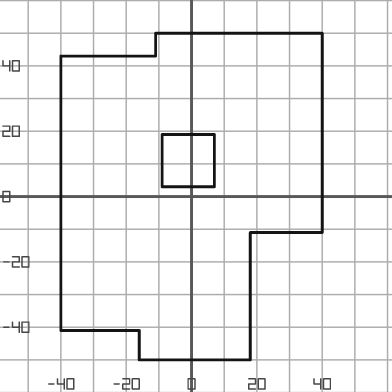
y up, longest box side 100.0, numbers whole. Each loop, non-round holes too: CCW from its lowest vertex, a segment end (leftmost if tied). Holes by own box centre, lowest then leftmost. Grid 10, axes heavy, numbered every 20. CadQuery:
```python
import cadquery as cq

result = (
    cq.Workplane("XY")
    .moveTo(-16.0, -50.0)
    .lineTo(18.0, -50.0)
    .lineTo(18.0, -11.0)
    .lineTo(40.0, -11.0)
    .lineTo(40.0, 50.0)
    .lineTo(-11.0, 50.0)
    .lineTo(-11.0, 43.0)
    .lineTo(-40.0, 43.0)
    .lineTo(-40.0, -41.0)
    .lineTo(-16.0, -41.0)
    .close()
    .moveTo(-9.0, 3.0)
    .lineTo(7.0, 3.0)
    .lineTo(7.0, 19.0)
    .lineTo(-9.0, 19.0)
    .close()
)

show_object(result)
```